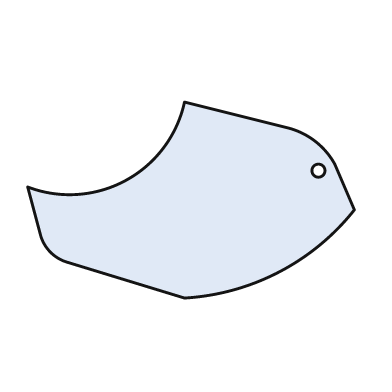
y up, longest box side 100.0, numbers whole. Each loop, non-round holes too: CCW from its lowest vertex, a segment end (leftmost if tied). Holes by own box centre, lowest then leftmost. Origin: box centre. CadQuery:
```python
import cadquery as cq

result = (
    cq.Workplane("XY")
    .moveTo(-2.0, -30.0)
    .threePointArc((27.0, -22.0), (50.0, -3.0))
    .lineTo(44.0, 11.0)
    .threePointArc((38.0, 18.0), (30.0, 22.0))
    .lineTo(-2.0, 30.0)
    .threePointArc((-20.0, 6.0), (-50.0, 4.0))
    .lineTo(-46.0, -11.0)
    .threePointArc((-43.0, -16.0), (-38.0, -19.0))
    .close()
    .moveTo(39.0, 9.0)
    .circle(2.0)
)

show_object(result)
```